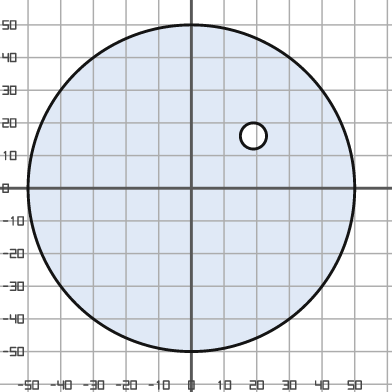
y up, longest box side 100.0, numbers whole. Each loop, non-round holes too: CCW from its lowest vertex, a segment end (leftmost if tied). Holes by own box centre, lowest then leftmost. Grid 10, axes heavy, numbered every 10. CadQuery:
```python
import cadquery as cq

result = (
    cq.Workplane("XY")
    .moveTo(0.0, 0.0)
    .circle(50.0)
    .moveTo(19.0, 16.0)
    .circle(4.0)
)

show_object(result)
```